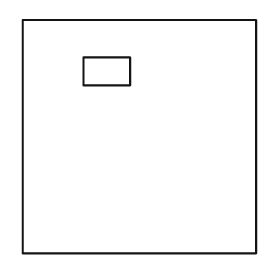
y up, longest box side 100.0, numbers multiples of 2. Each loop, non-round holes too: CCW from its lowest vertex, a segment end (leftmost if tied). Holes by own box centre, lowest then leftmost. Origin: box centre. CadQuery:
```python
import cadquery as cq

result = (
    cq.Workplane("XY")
    .moveTo(-50.0, -50.0)
    .lineTo(50.0, -50.0)
    .lineTo(50.0, 50.0)
    .lineTo(-50.0, 50.0)
    .close()
    .moveTo(-24.0, 22.0)
    .lineTo(-4.0, 22.0)
    .lineTo(-4.0, 34.0)
    .lineTo(-24.0, 34.0)
    .close()
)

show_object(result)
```